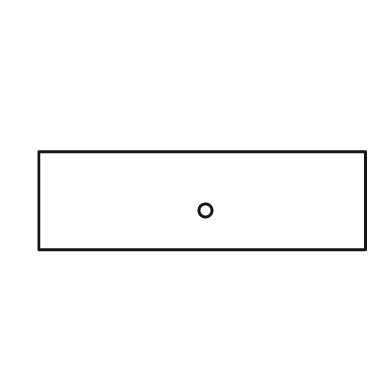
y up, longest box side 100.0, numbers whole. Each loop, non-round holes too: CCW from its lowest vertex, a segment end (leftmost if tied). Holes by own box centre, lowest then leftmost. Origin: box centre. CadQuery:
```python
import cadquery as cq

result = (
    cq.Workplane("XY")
    .moveTo(-50.0, -15.0)
    .lineTo(50.0, -15.0)
    .lineTo(50.0, 15.0)
    .lineTo(-50.0, 15.0)
    .close()
    .moveTo(1.0, -3.0)
    .circle(2.0)
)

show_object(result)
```